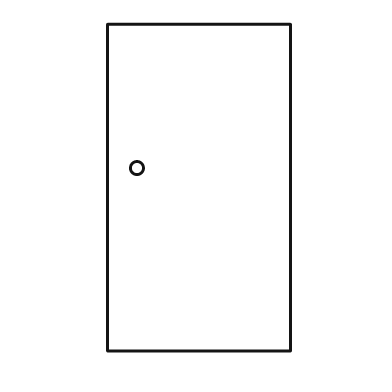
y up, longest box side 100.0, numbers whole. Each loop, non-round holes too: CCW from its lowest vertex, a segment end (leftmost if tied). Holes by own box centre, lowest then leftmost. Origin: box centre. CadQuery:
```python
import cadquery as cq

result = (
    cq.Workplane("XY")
    .moveTo(-28.0, -50.0)
    .lineTo(28.0, -50.0)
    .lineTo(28.0, 50.0)
    .lineTo(-28.0, 50.0)
    .close()
    .moveTo(-19.0, 6.0)
    .circle(2.0)
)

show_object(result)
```